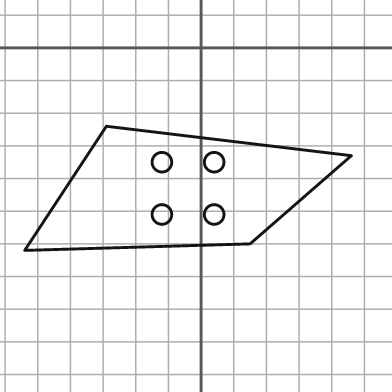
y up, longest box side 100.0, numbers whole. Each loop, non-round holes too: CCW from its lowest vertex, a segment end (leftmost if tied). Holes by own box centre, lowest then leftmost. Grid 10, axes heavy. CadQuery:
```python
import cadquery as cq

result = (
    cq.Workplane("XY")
    .moveTo(-54.0, -62.0)
    .lineTo(15.0, -60.0)
    .lineTo(46.0, -33.0)
    .lineTo(-29.0, -24.0)
    .close()
    .moveTo(-12.0, -51.0)
    .circle(3.0)
    .moveTo(4.0, -51.0)
    .circle(3.0)
    .moveTo(-12.0, -35.0)
    .circle(3.0)
    .moveTo(4.0, -35.0)
    .circle(3.0)
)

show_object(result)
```